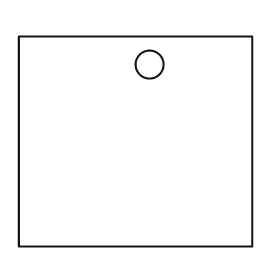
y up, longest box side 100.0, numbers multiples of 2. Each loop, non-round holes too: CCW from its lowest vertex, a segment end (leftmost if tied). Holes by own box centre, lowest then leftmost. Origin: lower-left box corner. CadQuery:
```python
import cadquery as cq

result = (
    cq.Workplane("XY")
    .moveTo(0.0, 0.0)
    .lineTo(100.0, 0.0)
    .lineTo(100.0, 90.0)
    .lineTo(0.0, 90.0)
    .close()
    .moveTo(56.0, 78.0)
    .circle(6.0)
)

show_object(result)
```